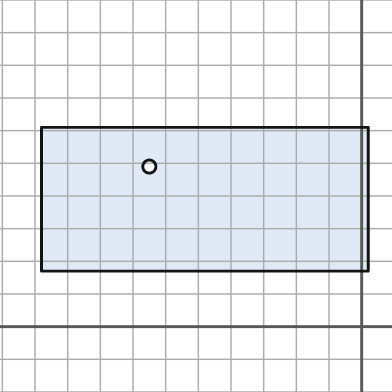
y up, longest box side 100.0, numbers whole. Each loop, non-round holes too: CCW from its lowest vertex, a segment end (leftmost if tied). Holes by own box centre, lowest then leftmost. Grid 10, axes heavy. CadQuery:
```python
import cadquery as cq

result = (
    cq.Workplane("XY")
    .moveTo(-98.0, 17.0)
    .lineTo(2.0, 17.0)
    .lineTo(2.0, 61.0)
    .lineTo(-98.0, 61.0)
    .close()
    .moveTo(-65.0, 49.0)
    .circle(2.0)
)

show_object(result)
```